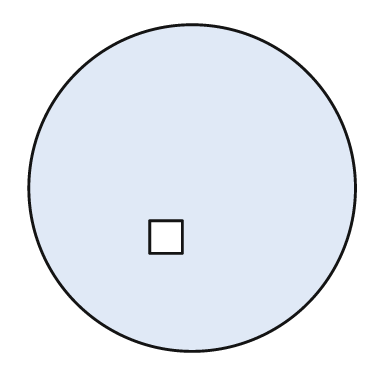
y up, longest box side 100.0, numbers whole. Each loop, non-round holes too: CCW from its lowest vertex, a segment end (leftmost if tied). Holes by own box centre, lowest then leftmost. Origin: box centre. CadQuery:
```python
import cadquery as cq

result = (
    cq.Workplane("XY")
    .moveTo(0.0, 0.0)
    .circle(50.0)
    .moveTo(-13.0, -20.0)
    .lineTo(-3.0, -20.0)
    .lineTo(-3.0, -10.0)
    .lineTo(-13.0, -10.0)
    .close()
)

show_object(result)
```